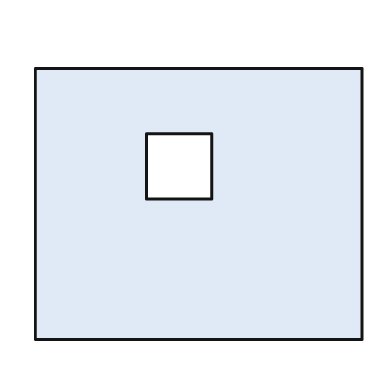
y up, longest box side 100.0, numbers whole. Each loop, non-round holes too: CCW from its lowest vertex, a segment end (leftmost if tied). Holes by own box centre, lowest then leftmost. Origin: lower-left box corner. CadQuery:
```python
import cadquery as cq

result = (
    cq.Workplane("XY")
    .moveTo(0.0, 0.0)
    .lineTo(100.0, 0.0)
    .lineTo(100.0, 83.0)
    .lineTo(0.0, 83.0)
    .close()
    .moveTo(34.0, 43.0)
    .lineTo(54.0, 43.0)
    .lineTo(54.0, 63.0)
    .lineTo(34.0, 63.0)
    .close()
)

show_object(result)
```